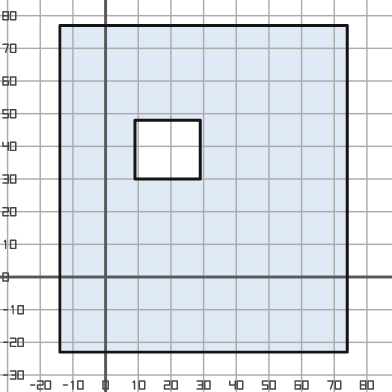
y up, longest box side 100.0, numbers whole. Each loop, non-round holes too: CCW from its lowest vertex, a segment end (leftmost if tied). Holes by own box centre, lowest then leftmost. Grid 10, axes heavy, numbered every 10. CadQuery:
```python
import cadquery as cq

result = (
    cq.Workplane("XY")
    .moveTo(-14.0, -23.0)
    .lineTo(74.0, -23.0)
    .lineTo(74.0, 77.0)
    .lineTo(-14.0, 77.0)
    .close()
    .moveTo(9.0, 30.0)
    .lineTo(29.0, 30.0)
    .lineTo(29.0, 48.0)
    .lineTo(9.0, 48.0)
    .close()
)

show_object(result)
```